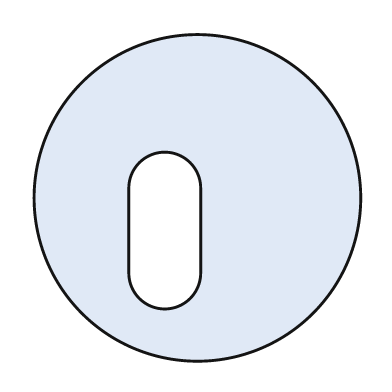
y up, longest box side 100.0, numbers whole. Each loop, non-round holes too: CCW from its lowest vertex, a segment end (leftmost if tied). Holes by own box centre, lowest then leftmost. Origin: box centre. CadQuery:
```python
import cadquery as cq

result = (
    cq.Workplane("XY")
    .moveTo(0.0, 0.0)
    .circle(50.0)
    .moveTo(-21.0, -23.0)
    .threePointArc((-10.0, -34.0), (1.0, -23.0))
    .lineTo(1.0, 3.0)
    .threePointArc((-10.0, 14.0), (-21.0, 3.0))
    .close()
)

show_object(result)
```